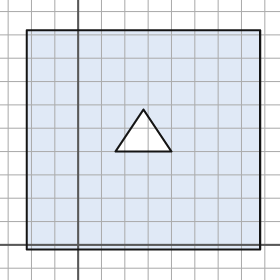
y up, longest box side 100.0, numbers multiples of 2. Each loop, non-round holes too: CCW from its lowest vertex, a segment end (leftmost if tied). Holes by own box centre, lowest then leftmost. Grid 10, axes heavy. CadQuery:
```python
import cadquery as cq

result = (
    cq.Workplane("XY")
    .moveTo(-22.0, -2.0)
    .lineTo(78.0, -2.0)
    .lineTo(78.0, 92.0)
    .lineTo(-22.0, 92.0)
    .close()
    .moveTo(16.0, 40.0)
    .lineTo(40.0, 40.0)
    .lineTo(28.0, 58.0)
    .close()
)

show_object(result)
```